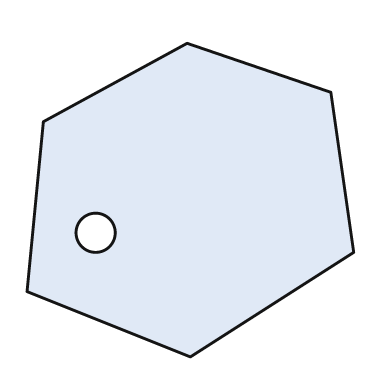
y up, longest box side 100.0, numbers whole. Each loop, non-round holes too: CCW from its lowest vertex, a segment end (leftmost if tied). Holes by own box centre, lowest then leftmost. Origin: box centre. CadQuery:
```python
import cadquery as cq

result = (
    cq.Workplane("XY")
    .moveTo(0.0, -48.0)
    .lineTo(50.0, -16.0)
    .lineTo(43.0, 33.0)
    .lineTo(-1.0, 48.0)
    .lineTo(-45.0, 24.0)
    .lineTo(-50.0, -28.0)
    .close()
    .moveTo(-29.0, -10.0)
    .circle(6.0)
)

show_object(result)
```